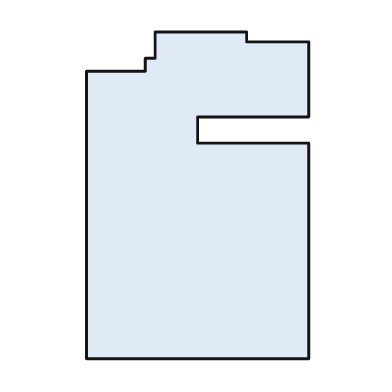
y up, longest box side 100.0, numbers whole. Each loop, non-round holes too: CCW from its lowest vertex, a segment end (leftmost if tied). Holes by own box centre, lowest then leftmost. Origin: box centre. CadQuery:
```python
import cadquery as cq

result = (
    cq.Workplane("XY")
    .moveTo(-34.0, -50.0)
    .lineTo(34.0, -50.0)
    .lineTo(34.0, 16.0)
    .lineTo(0.0, 16.0)
    .lineTo(0.0, 24.0)
    .lineTo(34.0, 24.0)
    .lineTo(34.0, 47.0)
    .lineTo(15.0, 47.0)
    .lineTo(15.0, 50.0)
    .lineTo(-13.0, 50.0)
    .lineTo(-13.0, 42.0)
    .lineTo(-16.0, 42.0)
    .lineTo(-16.0, 38.0)
    .lineTo(-34.0, 38.0)
    .close()
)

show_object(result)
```